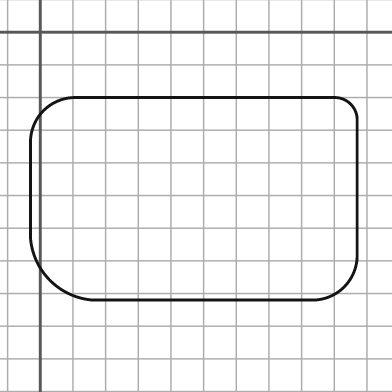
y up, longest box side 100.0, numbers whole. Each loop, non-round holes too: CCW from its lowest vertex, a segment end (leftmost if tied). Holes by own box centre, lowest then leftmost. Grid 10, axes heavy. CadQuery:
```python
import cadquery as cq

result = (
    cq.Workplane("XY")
    .moveTo(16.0, -82.0)
    .lineTo(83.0, -82.0)
    .threePointArc((93.0, -78.0), (97.0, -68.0))
    .lineTo(97.0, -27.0)
    .threePointArc((95.0, -22.0), (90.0, -20.0))
    .lineTo(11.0, -20.0)
    .threePointArc((1.0, -24.0), (-3.0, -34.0))
    .lineTo(-3.0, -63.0)
    .threePointArc((3.0, -76.0), (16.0, -82.0))
    .close()
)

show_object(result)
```